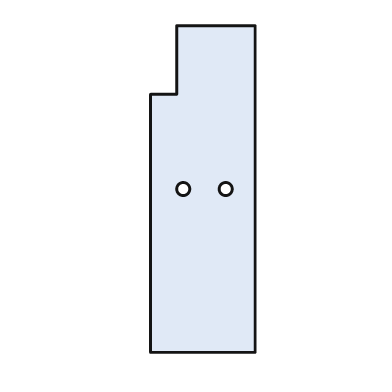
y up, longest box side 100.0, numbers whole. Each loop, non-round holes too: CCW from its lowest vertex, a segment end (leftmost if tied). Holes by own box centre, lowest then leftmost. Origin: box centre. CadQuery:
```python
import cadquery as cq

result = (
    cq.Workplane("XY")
    .moveTo(-16.0, -50.0)
    .lineTo(16.0, -50.0)
    .lineTo(16.0, 50.0)
    .lineTo(-8.0, 50.0)
    .lineTo(-8.0, 29.0)
    .lineTo(-16.0, 29.0)
    .close()
    .moveTo(-6.0, 0.0)
    .circle(2.0)
    .moveTo(7.0, 0.0)
    .circle(2.0)
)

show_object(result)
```